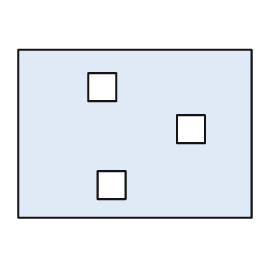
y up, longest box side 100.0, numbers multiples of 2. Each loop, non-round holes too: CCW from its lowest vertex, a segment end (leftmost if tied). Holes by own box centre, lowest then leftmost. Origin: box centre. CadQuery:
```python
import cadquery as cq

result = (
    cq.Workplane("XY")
    .moveTo(-50.0, -36.0)
    .lineTo(50.0, -36.0)
    .lineTo(50.0, 36.0)
    .lineTo(-50.0, 36.0)
    .close()
    .moveTo(-16.0, -28.0)
    .lineTo(-4.0, -28.0)
    .lineTo(-4.0, -16.0)
    .lineTo(-16.0, -16.0)
    .close()
    .moveTo(18.0, -4.0)
    .lineTo(30.0, -4.0)
    .lineTo(30.0, 8.0)
    .lineTo(18.0, 8.0)
    .close()
    .moveTo(-20.0, 14.0)
    .lineTo(-8.0, 14.0)
    .lineTo(-8.0, 26.0)
    .lineTo(-20.0, 26.0)
    .close()
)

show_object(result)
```